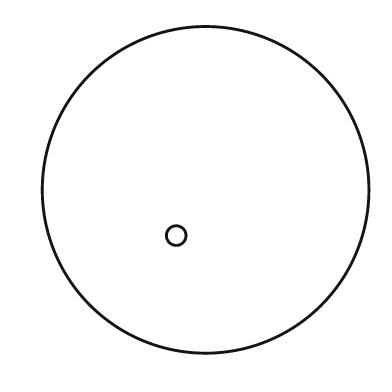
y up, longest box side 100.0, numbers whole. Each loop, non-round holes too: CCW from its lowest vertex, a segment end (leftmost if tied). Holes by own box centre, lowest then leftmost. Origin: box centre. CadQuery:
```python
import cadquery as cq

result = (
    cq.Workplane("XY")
    .moveTo(0.0, 0.0)
    .circle(50.0)
    .moveTo(-9.0, -14.0)
    .circle(3.0)
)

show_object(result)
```